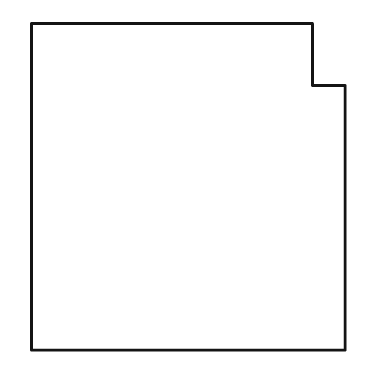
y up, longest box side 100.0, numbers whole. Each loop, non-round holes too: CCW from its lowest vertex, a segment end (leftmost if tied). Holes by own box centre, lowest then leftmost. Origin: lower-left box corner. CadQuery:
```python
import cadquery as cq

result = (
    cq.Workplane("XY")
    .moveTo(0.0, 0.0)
    .lineTo(96.0, 0.0)
    .lineTo(96.0, 81.0)
    .lineTo(86.0, 81.0)
    .lineTo(86.0, 100.0)
    .lineTo(0.0, 100.0)
    .close()
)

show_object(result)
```